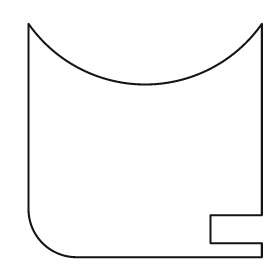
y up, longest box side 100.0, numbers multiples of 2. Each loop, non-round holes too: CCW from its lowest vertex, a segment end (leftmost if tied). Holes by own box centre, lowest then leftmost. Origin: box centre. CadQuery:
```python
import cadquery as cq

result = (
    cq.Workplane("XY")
    .moveTo(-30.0, -50.0)
    .lineTo(50.0, -50.0)
    .lineTo(50.0, -44.0)
    .lineTo(28.0, -44.0)
    .lineTo(28.0, -32.0)
    .lineTo(50.0, -32.0)
    .lineTo(50.0, 50.0)
    .threePointArc((0.0, 24.0), (-50.0, 50.0))
    .lineTo(-50.0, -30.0)
    .threePointArc((-44.0, -44.0), (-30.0, -50.0))
    .close()
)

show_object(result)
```